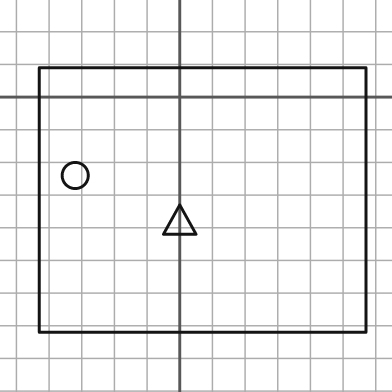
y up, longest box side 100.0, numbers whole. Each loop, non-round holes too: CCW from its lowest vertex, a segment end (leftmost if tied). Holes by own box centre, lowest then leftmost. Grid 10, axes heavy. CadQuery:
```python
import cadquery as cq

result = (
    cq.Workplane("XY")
    .moveTo(-43.0, -72.0)
    .lineTo(57.0, -72.0)
    .lineTo(57.0, 9.0)
    .lineTo(-43.0, 9.0)
    .close()
    .moveTo(-5.0, -42.0)
    .lineTo(5.0, -42.0)
    .lineTo(0.0, -33.0)
    .close()
    .moveTo(-32.0, -24.0)
    .circle(4.0)
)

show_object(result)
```